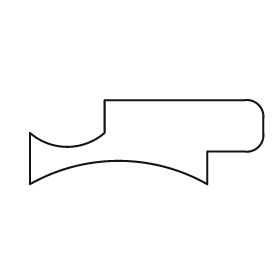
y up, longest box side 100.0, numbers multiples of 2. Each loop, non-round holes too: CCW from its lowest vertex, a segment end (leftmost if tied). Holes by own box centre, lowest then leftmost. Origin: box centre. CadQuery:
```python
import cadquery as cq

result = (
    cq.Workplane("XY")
    .moveTo(-50.0, -18.0)
    .threePointArc((-12.0, -8.0), (26.0, -18.0))
    .lineTo(26.0, -4.0)
    .lineTo(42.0, -4.0)
    .threePointArc((48.0, -2.0), (50.0, 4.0))
    .lineTo(50.0, 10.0)
    .threePointArc((48.0, 16.0), (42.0, 18.0))
    .lineTo(-18.0, 18.0)
    .lineTo(-18.0, 4.0)
    .threePointArc((-34.0, -2.0), (-50.0, 4.0))
    .close()
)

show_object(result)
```